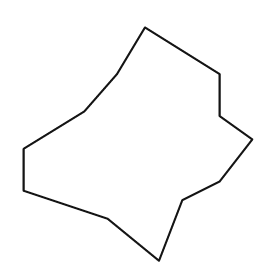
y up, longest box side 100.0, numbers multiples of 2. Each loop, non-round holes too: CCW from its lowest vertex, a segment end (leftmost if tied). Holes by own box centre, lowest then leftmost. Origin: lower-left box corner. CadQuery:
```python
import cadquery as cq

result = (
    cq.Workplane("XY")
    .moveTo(58.0, 0.0)
    .lineTo(68.0, 26.0)
    .lineTo(84.0, 34.0)
    .lineTo(98.0, 52.0)
    .lineTo(84.0, 62.0)
    .lineTo(84.0, 80.0)
    .lineTo(52.0, 100.0)
    .lineTo(40.0, 80.0)
    .lineTo(26.0, 64.0)
    .lineTo(0.0, 48.0)
    .lineTo(0.0, 30.0)
    .lineTo(36.0, 18.0)
    .close()
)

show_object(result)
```